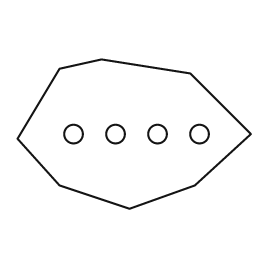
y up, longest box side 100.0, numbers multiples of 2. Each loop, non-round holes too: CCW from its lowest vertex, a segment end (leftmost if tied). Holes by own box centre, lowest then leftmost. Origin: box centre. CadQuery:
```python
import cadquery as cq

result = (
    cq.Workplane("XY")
    .moveTo(-2.0, -32.0)
    .lineTo(26.0, -22.0)
    .lineTo(50.0, 0.0)
    .lineTo(24.0, 26.0)
    .lineTo(-14.0, 32.0)
    .lineTo(-32.0, 28.0)
    .lineTo(-50.0, -2.0)
    .lineTo(-32.0, -22.0)
    .close()
    .moveTo(-26.0, 0.0)
    .circle(4.0)
    .moveTo(-8.0, 0.0)
    .circle(4.0)
    .moveTo(10.0, 0.0)
    .circle(4.0)
    .moveTo(28.0, 0.0)
    .circle(4.0)
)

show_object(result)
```